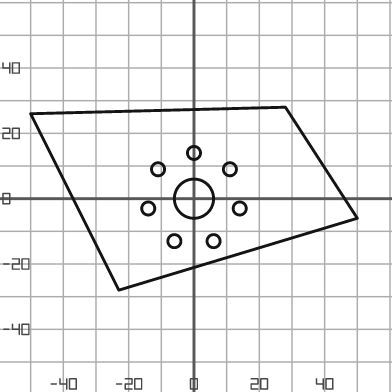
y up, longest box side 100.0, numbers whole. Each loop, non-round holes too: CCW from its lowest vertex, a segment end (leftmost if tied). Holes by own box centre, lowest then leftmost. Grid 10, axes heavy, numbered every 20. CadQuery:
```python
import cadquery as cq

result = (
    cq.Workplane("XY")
    .moveTo(-23.0, -28.0)
    .lineTo(50.0, -6.0)
    .lineTo(28.0, 28.0)
    .lineTo(-50.0, 26.0)
    .close()
    .moveTo(-6.0, -13.0)
    .circle(2.0)
    .moveTo(6.0, -13.0)
    .circle(2.0)
    .moveTo(-14.0, -3.0)
    .circle(2.0)
    .moveTo(14.0, -3.0)
    .circle(2.0)
    .moveTo(0.0, 0.0)
    .circle(6.0)
    .moveTo(-11.0, 9.0)
    .circle(2.0)
    .moveTo(11.0, 9.0)
    .circle(2.0)
    .moveTo(0.0, 14.0)
    .circle(2.0)
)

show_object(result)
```